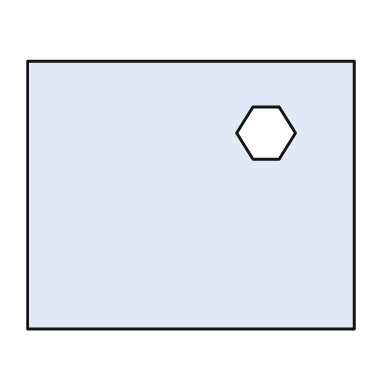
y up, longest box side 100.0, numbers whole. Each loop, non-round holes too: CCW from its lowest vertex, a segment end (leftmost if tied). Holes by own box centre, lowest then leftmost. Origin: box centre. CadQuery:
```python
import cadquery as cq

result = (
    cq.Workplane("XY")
    .moveTo(-50.0, -41.0)
    .lineTo(50.0, -41.0)
    .lineTo(50.0, 41.0)
    .lineTo(-50.0, 41.0)
    .close()
    .moveTo(19.0, 11.0)
    .lineTo(27.0, 11.0)
    .lineTo(32.0, 19.0)
    .lineTo(27.0, 27.0)
    .lineTo(19.0, 27.0)
    .lineTo(14.0, 19.0)
    .close()
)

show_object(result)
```